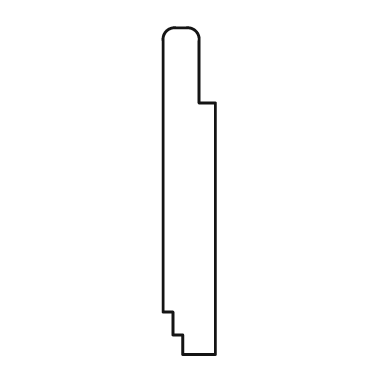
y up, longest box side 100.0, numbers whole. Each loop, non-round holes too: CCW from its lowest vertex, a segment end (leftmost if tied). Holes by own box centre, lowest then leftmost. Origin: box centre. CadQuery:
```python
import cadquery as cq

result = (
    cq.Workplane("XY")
    .moveTo(-2.0, -50.0)
    .lineTo(8.0, -50.0)
    .lineTo(8.0, 27.0)
    .lineTo(3.0, 27.0)
    .lineTo(3.0, 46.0)
    .threePointArc((2.0, 49.0), (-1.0, 50.0))
    .lineTo(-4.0, 50.0)
    .threePointArc((-7.0, 49.0), (-8.0, 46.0))
    .lineTo(-8.0, -37.0)
    .lineTo(-5.0, -37.0)
    .lineTo(-5.0, -44.0)
    .lineTo(-2.0, -44.0)
    .close()
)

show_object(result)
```